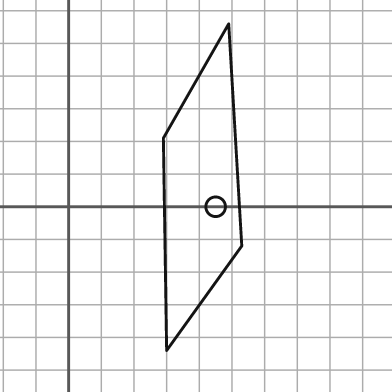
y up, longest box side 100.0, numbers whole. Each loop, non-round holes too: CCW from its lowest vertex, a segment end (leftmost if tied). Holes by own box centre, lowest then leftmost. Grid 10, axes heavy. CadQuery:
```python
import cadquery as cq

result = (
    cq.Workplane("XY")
    .moveTo(30.0, -44.0)
    .lineTo(53.0, -12.0)
    .lineTo(49.0, 56.0)
    .lineTo(29.0, 21.0)
    .close()
    .moveTo(45.0, 0.0)
    .circle(3.0)
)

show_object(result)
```